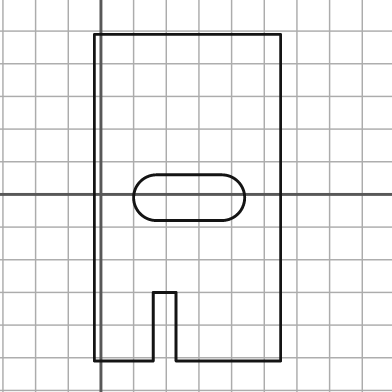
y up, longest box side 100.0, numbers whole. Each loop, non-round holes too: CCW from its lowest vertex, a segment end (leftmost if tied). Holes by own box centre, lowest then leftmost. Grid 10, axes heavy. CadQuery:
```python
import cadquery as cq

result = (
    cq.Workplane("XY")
    .moveTo(-2.0, -51.0)
    .lineTo(16.0, -51.0)
    .lineTo(16.0, -30.0)
    .lineTo(23.0, -30.0)
    .lineTo(23.0, -51.0)
    .lineTo(55.0, -51.0)
    .lineTo(55.0, 49.0)
    .lineTo(-2.0, 49.0)
    .close()
    .moveTo(17.0, -8.0)
    .lineTo(37.0, -8.0)
    .threePointArc((44.0, -1.0), (37.0, 6.0))
    .lineTo(17.0, 6.0)
    .threePointArc((10.0, -1.0), (17.0, -8.0))
    .close()
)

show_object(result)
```